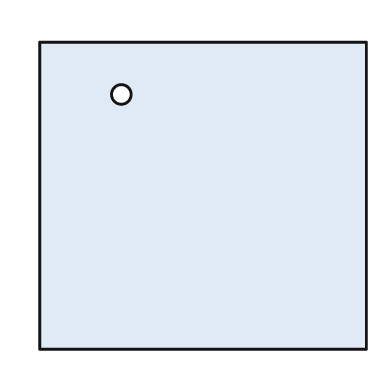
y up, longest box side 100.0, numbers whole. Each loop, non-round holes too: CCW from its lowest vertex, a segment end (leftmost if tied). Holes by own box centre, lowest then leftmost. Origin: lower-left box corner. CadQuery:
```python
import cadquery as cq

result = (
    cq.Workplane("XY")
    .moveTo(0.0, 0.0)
    .lineTo(100.0, 0.0)
    .lineTo(100.0, 94.0)
    .lineTo(0.0, 94.0)
    .close()
    .moveTo(25.0, 78.0)
    .circle(3.0)
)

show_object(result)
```